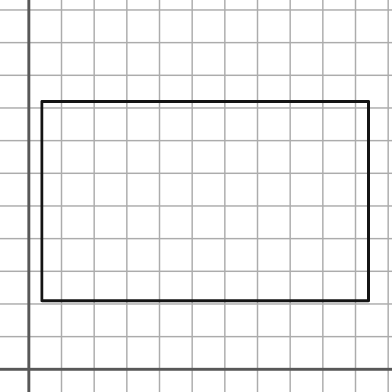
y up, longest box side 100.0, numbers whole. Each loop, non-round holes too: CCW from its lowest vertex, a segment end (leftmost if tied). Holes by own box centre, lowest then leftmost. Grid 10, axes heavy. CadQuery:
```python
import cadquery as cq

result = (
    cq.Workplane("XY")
    .moveTo(4.0, 21.0)
    .lineTo(104.0, 21.0)
    .lineTo(104.0, 82.0)
    .lineTo(4.0, 82.0)
    .close()
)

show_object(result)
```